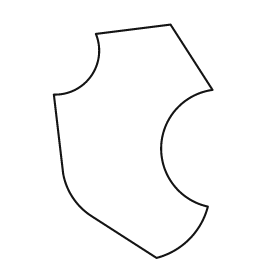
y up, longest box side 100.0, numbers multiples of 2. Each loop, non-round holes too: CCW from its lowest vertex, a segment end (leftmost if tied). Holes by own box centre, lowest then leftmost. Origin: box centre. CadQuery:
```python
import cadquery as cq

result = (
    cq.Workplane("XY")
    .moveTo(10.0, -50.0)
    .threePointArc((24.0, -42.0), (32.0, -28.0))
    .threePointArc((12.0, -2.0), (34.0, 22.0))
    .lineTo(16.0, 50.0)
    .lineTo(-16.0, 46.0)
    .threePointArc((-18.0, 28.0), (-34.0, 20.0))
    .lineTo(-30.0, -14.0)
    .threePointArc((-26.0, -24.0), (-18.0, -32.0))
    .close()
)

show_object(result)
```